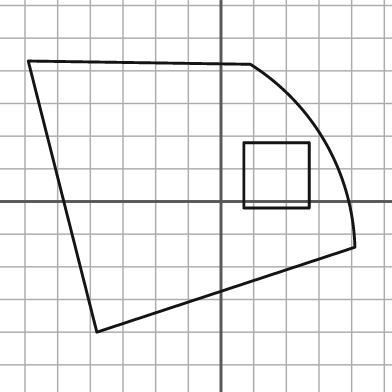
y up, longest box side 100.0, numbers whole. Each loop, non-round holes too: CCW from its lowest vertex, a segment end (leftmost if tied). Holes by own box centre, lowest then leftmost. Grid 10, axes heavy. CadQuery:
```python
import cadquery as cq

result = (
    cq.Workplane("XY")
    .moveTo(-38.0, -40.0)
    .lineTo(41.0, -14.0)
    .threePointArc((32.0, 18.0), (9.0, 42.0))
    .lineTo(-59.0, 43.0)
    .close()
    .moveTo(7.0, -2.0)
    .lineTo(27.0, -2.0)
    .lineTo(27.0, 18.0)
    .lineTo(7.0, 18.0)
    .close()
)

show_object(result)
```